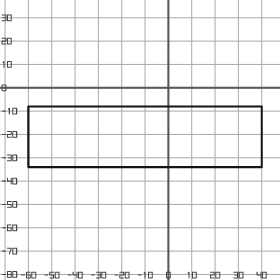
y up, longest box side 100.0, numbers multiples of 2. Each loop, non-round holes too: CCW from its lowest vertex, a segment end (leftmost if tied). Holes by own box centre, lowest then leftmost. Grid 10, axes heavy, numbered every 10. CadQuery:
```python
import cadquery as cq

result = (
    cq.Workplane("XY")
    .moveTo(-60.0, -34.0)
    .lineTo(40.0, -34.0)
    .lineTo(40.0, -8.0)
    .lineTo(-60.0, -8.0)
    .close()
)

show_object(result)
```